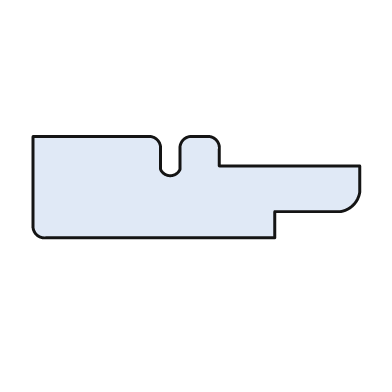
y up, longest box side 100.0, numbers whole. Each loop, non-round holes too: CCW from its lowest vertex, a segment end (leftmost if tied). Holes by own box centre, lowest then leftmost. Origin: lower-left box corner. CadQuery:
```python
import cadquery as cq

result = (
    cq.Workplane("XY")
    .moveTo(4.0, 0.0)
    .lineTo(74.0, 0.0)
    .lineTo(74.0, 8.0)
    .lineTo(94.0, 8.0)
    .threePointArc((98.0, 10.0), (100.0, 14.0))
    .lineTo(100.0, 22.0)
    .lineTo(57.0, 22.0)
    .lineTo(57.0, 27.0)
    .threePointArc((56.0, 30.0), (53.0, 31.0))
    .lineTo(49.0, 31.0)
    .threePointArc((46.0, 30.0), (45.0, 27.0))
    .lineTo(45.0, 21.0)
    .threePointArc((42.0, 19.0), (39.0, 21.0))
    .lineTo(39.0, 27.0)
    .threePointArc((38.0, 30.0), (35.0, 31.0))
    .lineTo(0.0, 31.0)
    .lineTo(0.0, 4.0)
    .threePointArc((1.0, 1.0), (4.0, 0.0))
    .close()
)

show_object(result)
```